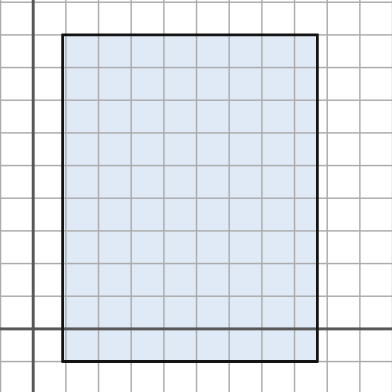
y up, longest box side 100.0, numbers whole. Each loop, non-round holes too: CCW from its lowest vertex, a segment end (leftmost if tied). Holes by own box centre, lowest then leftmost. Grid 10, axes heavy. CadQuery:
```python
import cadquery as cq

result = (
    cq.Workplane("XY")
    .moveTo(9.0, -10.0)
    .lineTo(87.0, -10.0)
    .lineTo(87.0, 90.0)
    .lineTo(9.0, 90.0)
    .close()
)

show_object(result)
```